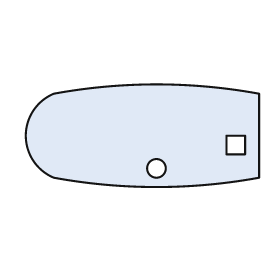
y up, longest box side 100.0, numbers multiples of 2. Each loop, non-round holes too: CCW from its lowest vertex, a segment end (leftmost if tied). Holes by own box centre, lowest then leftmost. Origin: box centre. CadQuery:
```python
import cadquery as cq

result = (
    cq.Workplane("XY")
    .moveTo(-38.0, -18.0)
    .threePointArc((6.0, -22.0), (50.0, -18.0))
    .lineTo(50.0, 18.0)
    .threePointArc((6.0, 22.0), (-38.0, 18.0))
    .threePointArc((-50.0, 0.0), (-38.0, -18.0))
    .close()
    .moveTo(6.0, -14.0)
    .circle(4.0)
    .moveTo(36.0, -8.0)
    .lineTo(44.0, -8.0)
    .lineTo(44.0, 0.0)
    .lineTo(36.0, 0.0)
    .close()
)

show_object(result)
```